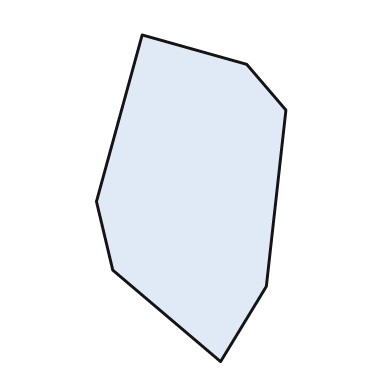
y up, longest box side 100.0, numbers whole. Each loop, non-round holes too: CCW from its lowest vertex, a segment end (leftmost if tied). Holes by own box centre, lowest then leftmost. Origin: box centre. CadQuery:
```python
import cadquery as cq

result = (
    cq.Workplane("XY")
    .moveTo(9.0, -50.0)
    .lineTo(23.0, -27.0)
    .lineTo(29.0, 27.0)
    .lineTo(17.0, 41.0)
    .lineTo(-15.0, 50.0)
    .lineTo(-29.0, -1.0)
    .lineTo(-24.0, -22.0)
    .close()
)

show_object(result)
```